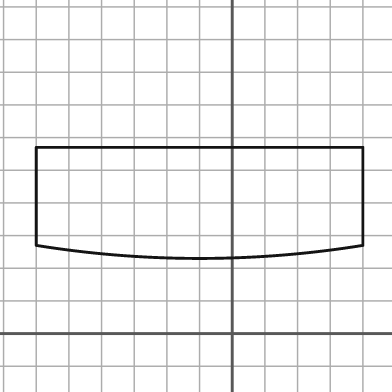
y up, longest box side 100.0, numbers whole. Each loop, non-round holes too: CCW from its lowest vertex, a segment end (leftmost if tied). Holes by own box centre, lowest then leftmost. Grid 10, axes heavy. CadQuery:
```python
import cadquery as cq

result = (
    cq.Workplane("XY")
    .moveTo(-60.0, 27.0)
    .threePointArc((-10.0, 23.0), (40.0, 27.0))
    .lineTo(40.0, 57.0)
    .lineTo(-60.0, 57.0)
    .close()
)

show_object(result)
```